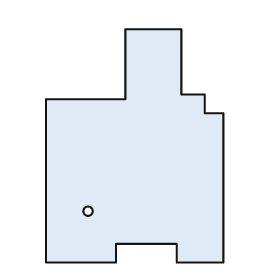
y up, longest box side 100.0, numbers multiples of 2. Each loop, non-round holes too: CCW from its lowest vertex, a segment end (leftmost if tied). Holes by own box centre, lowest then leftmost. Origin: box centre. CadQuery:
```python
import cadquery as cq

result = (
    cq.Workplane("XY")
    .moveTo(-38.0, -50.0)
    .lineTo(-8.0, -50.0)
    .lineTo(-8.0, -42.0)
    .lineTo(18.0, -42.0)
    .lineTo(18.0, -50.0)
    .lineTo(38.0, -50.0)
    .lineTo(38.0, 14.0)
    .lineTo(30.0, 14.0)
    .lineTo(30.0, 22.0)
    .lineTo(20.0, 22.0)
    .lineTo(20.0, 50.0)
    .lineTo(-4.0, 50.0)
    .lineTo(-4.0, 20.0)
    .lineTo(-38.0, 20.0)
    .close()
    .moveTo(-20.0, -28.0)
    .circle(2.0)
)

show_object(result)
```